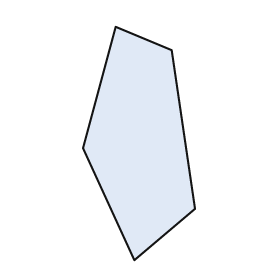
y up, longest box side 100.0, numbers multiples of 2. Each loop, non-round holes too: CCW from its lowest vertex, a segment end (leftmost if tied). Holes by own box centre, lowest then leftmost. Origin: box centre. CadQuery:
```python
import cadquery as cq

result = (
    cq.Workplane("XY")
    .moveTo(-2.0, -50.0)
    .lineTo(24.0, -28.0)
    .lineTo(14.0, 40.0)
    .lineTo(-10.0, 50.0)
    .lineTo(-24.0, -2.0)
    .close()
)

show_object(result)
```